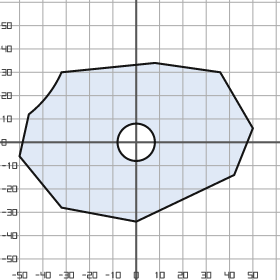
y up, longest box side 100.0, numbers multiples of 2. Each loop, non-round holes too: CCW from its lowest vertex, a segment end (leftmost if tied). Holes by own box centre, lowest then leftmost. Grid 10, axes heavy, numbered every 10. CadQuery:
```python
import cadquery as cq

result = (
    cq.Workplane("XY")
    .moveTo(0.0, -34.0)
    .lineTo(42.0, -14.0)
    .lineTo(50.0, 6.0)
    .lineTo(36.0, 30.0)
    .lineTo(8.0, 34.0)
    .lineTo(-32.0, 30.0)
    .threePointArc((-38.0, 20.0), (-46.0, 12.0))
    .lineTo(-50.0, -6.0)
    .lineTo(-32.0, -28.0)
    .close()
    .moveTo(0.0, 0.0)
    .circle(8.0)
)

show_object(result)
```